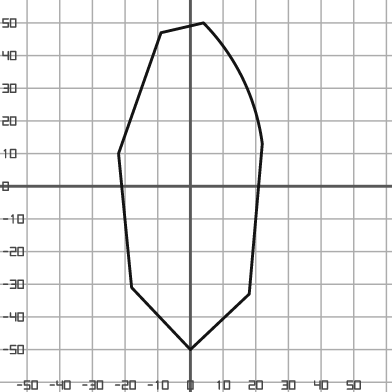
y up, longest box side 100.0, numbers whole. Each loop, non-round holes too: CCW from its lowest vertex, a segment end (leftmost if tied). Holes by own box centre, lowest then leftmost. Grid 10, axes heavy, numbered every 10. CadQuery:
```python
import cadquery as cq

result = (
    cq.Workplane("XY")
    .moveTo(0.0, -50.0)
    .lineTo(18.0, -33.0)
    .lineTo(22.0, 13.0)
    .threePointArc((16.0, 33.0), (4.0, 50.0))
    .lineTo(-9.0, 47.0)
    .lineTo(-22.0, 10.0)
    .lineTo(-18.0, -31.0)
    .close()
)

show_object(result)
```